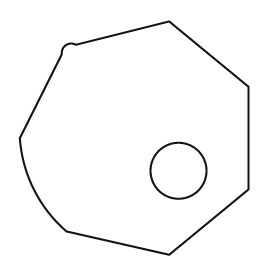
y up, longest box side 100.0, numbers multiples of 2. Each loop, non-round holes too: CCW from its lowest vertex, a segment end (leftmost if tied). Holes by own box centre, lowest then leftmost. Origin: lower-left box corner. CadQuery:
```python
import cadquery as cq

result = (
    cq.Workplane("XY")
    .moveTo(64.0, 0.0)
    .lineTo(98.0, 28.0)
    .lineTo(98.0, 72.0)
    .lineTo(64.0, 100.0)
    .lineTo(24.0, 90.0)
    .threePointArc((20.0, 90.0), (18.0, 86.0))
    .lineTo(0.0, 50.0)
    .threePointArc((6.0, 28.0), (20.0, 10.0))
    .close()
    .moveTo(68.0, 36.0)
    .circle(12.0)
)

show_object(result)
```